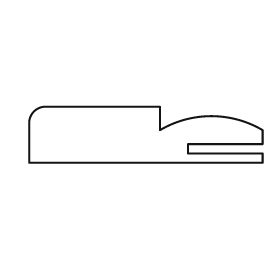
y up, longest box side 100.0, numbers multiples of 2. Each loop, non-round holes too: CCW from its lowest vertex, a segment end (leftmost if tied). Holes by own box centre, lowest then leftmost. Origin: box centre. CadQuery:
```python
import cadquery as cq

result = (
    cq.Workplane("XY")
    .moveTo(-50.0, -12.0)
    .lineTo(50.0, -12.0)
    .lineTo(50.0, -8.0)
    .lineTo(18.0, -8.0)
    .lineTo(18.0, -4.0)
    .lineTo(50.0, -4.0)
    .lineTo(50.0, 2.0)
    .threePointArc((28.0, 8.0), (6.0, 2.0))
    .lineTo(6.0, 12.0)
    .lineTo(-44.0, 12.0)
    .threePointArc((-48.0, 10.0), (-50.0, 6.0))
    .close()
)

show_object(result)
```